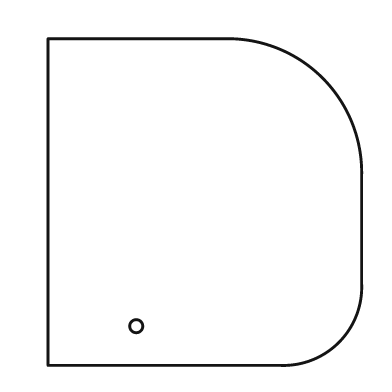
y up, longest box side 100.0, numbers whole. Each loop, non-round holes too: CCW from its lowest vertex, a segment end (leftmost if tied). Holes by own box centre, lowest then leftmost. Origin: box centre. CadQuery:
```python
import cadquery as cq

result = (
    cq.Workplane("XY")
    .moveTo(-48.0, -50.0)
    .lineTo(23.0, -50.0)
    .threePointArc((41.0, -43.0), (48.0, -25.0))
    .lineTo(48.0, 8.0)
    .threePointArc((36.0, 38.0), (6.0, 50.0))
    .lineTo(-48.0, 50.0)
    .close()
    .moveTo(-21.0, -38.0)
    .circle(2.0)
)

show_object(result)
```